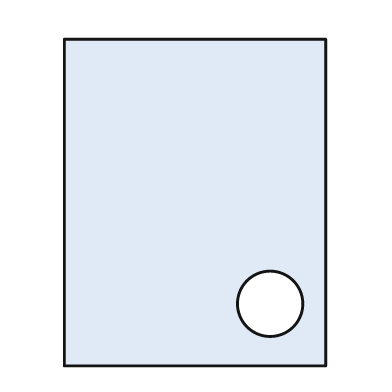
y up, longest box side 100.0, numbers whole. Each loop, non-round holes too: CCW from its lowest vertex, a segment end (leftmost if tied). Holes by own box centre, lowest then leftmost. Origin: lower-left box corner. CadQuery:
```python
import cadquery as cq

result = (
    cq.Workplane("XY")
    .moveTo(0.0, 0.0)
    .lineTo(80.0, 0.0)
    .lineTo(80.0, 100.0)
    .lineTo(0.0, 100.0)
    .close()
    .moveTo(63.0, 19.0)
    .circle(10.0)
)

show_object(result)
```